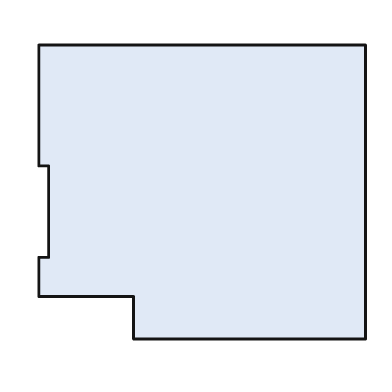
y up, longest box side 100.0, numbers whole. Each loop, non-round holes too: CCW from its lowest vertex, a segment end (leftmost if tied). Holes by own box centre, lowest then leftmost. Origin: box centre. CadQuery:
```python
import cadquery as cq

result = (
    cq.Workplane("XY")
    .moveTo(-21.0, -45.0)
    .lineTo(50.0, -45.0)
    .lineTo(50.0, 45.0)
    .lineTo(-50.0, 45.0)
    .lineTo(-50.0, 8.0)
    .lineTo(-47.0, 8.0)
    .lineTo(-47.0, -20.0)
    .lineTo(-50.0, -20.0)
    .lineTo(-50.0, -32.0)
    .lineTo(-21.0, -32.0)
    .close()
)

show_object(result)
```